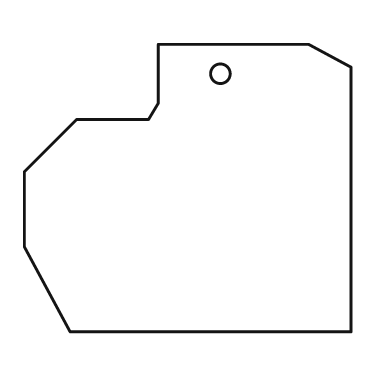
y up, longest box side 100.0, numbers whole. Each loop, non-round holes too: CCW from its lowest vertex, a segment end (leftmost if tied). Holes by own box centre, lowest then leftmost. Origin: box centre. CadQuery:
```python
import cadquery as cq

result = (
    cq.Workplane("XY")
    .moveTo(-36.0, -44.0)
    .lineTo(50.0, -44.0)
    .lineTo(50.0, 37.0)
    .lineTo(37.0, 44.0)
    .lineTo(-9.0, 44.0)
    .lineTo(-9.0, 26.0)
    .lineTo(-12.0, 21.0)
    .lineTo(-34.0, 21.0)
    .lineTo(-50.0, 5.0)
    .lineTo(-50.0, -18.0)
    .close()
    .moveTo(10.0, 35.0)
    .circle(3.0)
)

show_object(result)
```